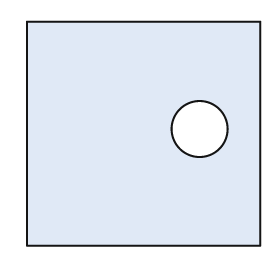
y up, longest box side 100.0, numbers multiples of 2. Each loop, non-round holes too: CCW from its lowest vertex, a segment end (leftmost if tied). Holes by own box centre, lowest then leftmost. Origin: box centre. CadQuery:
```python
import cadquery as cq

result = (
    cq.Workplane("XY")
    .moveTo(-50.0, -48.0)
    .lineTo(50.0, -48.0)
    .lineTo(50.0, 48.0)
    .lineTo(-50.0, 48.0)
    .close()
    .moveTo(24.0, 2.0)
    .circle(12.0)
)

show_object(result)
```